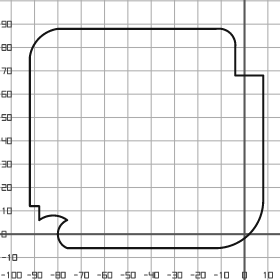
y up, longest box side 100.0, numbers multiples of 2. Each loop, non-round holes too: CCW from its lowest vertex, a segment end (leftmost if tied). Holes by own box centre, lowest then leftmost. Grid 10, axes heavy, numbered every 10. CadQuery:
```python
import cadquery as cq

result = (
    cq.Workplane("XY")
    .moveTo(-76.0, -6.0)
    .lineTo(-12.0, -6.0)
    .threePointArc((2.0, 0.0), (8.0, 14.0))
    .lineTo(8.0, 68.0)
    .lineTo(-4.0, 68.0)
    .lineTo(-4.0, 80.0)
    .threePointArc((-6.0, 86.0), (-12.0, 88.0))
    .lineTo(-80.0, 88.0)
    .threePointArc((-88.0, 84.0), (-92.0, 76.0))
    .lineTo(-92.0, 12.0)
    .lineTo(-88.0, 12.0)
    .lineTo(-88.0, 6.0)
    .threePointArc((-82.0, 8.0), (-76.0, 6.0))
    .threePointArc((-80.0, 0.0), (-76.0, -6.0))
    .close()
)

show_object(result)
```